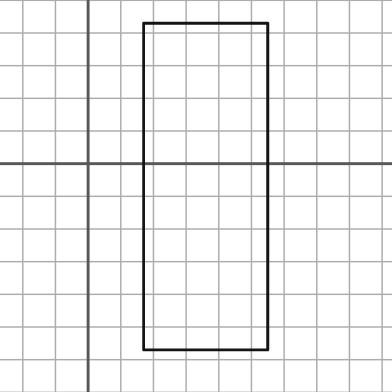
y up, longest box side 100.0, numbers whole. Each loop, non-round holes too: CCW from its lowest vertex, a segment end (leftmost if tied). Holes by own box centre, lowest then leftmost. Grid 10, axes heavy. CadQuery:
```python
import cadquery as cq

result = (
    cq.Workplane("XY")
    .moveTo(17.0, -57.0)
    .lineTo(55.0, -57.0)
    .lineTo(55.0, 43.0)
    .lineTo(17.0, 43.0)
    .close()
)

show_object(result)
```